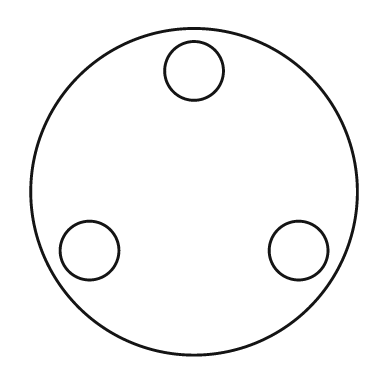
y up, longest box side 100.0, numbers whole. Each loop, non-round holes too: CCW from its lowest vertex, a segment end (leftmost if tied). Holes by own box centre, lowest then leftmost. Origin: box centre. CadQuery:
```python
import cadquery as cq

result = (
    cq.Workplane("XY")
    .moveTo(0.0, 0.0)
    .circle(50.0)
    .moveTo(-32.0, -18.0)
    .circle(9.0)
    .moveTo(32.0, -18.0)
    .circle(9.0)
    .moveTo(0.0, 37.0)
    .circle(9.0)
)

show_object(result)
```